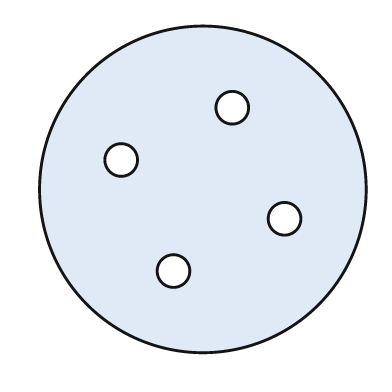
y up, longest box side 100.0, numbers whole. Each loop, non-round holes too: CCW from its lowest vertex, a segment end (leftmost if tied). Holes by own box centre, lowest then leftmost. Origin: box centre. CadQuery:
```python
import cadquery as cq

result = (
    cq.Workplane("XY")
    .moveTo(0.0, 0.0)
    .circle(50.0)
    .moveTo(-9.0, -25.0)
    .circle(5.0)
    .moveTo(25.0, -9.0)
    .circle(5.0)
    .moveTo(-25.0, 9.0)
    .circle(5.0)
    .moveTo(9.0, 25.0)
    .circle(5.0)
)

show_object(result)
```